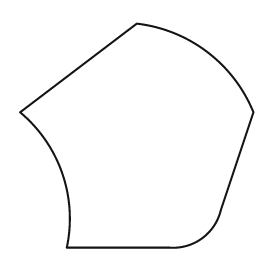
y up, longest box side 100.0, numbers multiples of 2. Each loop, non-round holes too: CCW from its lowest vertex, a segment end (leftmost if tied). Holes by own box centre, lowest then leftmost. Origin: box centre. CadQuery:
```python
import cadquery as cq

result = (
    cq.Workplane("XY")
    .moveTo(-30.0, -48.0)
    .lineTo(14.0, -48.0)
    .threePointArc((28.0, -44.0), (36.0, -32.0))
    .lineTo(50.0, 10.0)
    .threePointArc((30.0, 36.0), (0.0, 48.0))
    .lineTo(-50.0, 10.0)
    .threePointArc((-32.0, -16.0), (-30.0, -48.0))
    .close()
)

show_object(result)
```